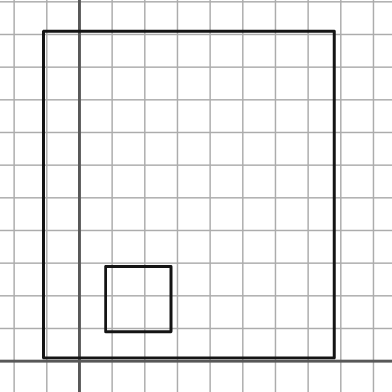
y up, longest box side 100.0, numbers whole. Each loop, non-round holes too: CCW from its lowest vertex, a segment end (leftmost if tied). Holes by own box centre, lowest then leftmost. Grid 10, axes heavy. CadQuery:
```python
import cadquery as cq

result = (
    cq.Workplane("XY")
    .moveTo(-11.0, 1.0)
    .lineTo(78.0, 1.0)
    .lineTo(78.0, 101.0)
    .lineTo(-11.0, 101.0)
    .close()
    .moveTo(8.0, 9.0)
    .lineTo(28.0, 9.0)
    .lineTo(28.0, 29.0)
    .lineTo(8.0, 29.0)
    .close()
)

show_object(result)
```